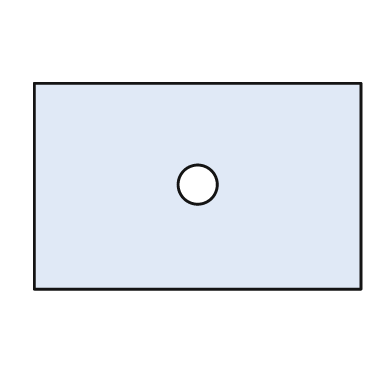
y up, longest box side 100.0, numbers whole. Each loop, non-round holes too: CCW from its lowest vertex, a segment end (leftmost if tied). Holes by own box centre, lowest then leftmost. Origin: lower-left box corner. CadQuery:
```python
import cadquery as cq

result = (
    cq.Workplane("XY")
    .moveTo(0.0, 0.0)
    .lineTo(100.0, 0.0)
    .lineTo(100.0, 63.0)
    .lineTo(0.0, 63.0)
    .close()
    .moveTo(50.0, 32.0)
    .circle(6.0)
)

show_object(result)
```